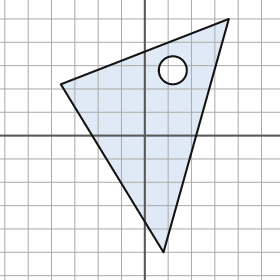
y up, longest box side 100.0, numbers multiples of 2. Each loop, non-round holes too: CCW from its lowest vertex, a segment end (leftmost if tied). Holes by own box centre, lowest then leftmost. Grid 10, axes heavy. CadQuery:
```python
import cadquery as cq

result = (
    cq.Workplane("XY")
    .moveTo(8.0, -50.0)
    .lineTo(36.0, 50.0)
    .lineTo(-36.0, 22.0)
    .close()
    .moveTo(12.0, 28.0)
    .circle(6.0)
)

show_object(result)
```